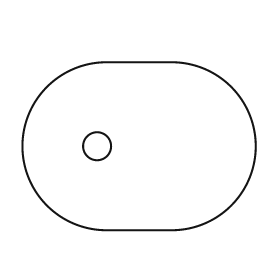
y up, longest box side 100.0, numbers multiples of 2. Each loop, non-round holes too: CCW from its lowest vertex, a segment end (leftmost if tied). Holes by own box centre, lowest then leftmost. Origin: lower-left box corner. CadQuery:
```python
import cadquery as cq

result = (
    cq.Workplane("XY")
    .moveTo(36.0, 0.0)
    .lineTo(64.0, 0.0)
    .threePointArc((100.0, 36.0), (64.0, 72.0))
    .lineTo(36.0, 72.0)
    .threePointArc((0.0, 36.0), (36.0, 0.0))
    .close()
    .moveTo(32.0, 36.0)
    .circle(6.0)
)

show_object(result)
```